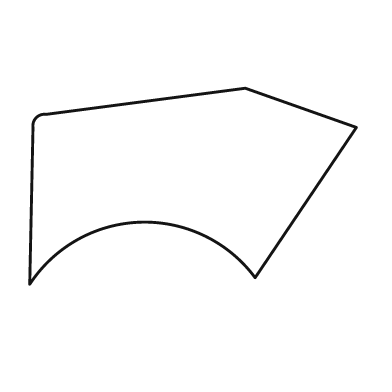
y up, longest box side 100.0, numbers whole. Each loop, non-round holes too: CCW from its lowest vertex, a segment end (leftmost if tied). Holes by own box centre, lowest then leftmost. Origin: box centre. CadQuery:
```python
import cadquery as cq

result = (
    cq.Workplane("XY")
    .moveTo(-50.0, -30.0)
    .threePointArc((-16.0, -11.0), (19.0, -28.0))
    .lineTo(50.0, 18.0)
    .lineTo(16.0, 30.0)
    .lineTo(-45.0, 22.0)
    .threePointArc((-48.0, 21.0), (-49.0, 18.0))
    .close()
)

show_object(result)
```